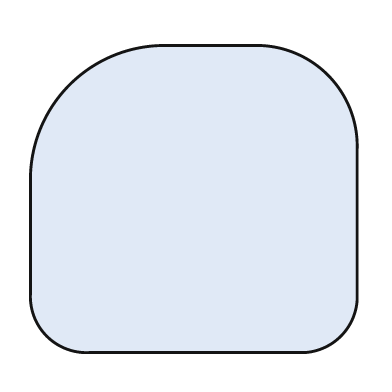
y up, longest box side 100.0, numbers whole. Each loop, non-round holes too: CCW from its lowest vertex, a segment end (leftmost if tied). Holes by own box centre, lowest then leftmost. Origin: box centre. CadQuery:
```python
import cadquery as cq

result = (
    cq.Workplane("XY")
    .moveTo(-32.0, -47.0)
    .lineTo(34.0, -47.0)
    .threePointArc((45.0, -42.0), (50.0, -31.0))
    .lineTo(50.0, 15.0)
    .threePointArc((41.0, 38.0), (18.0, 47.0))
    .lineTo(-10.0, 47.0)
    .threePointArc((-38.0, 35.0), (-50.0, 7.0))
    .lineTo(-50.0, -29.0)
    .threePointArc((-45.0, -42.0), (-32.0, -47.0))
    .close()
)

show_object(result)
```